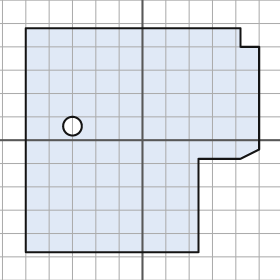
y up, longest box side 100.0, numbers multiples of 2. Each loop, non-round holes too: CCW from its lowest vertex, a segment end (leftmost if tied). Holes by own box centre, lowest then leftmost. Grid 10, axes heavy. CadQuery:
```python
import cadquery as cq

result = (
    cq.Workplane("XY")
    .moveTo(-50.0, -48.0)
    .lineTo(24.0, -48.0)
    .lineTo(24.0, -8.0)
    .lineTo(42.0, -8.0)
    .lineTo(50.0, -4.0)
    .lineTo(50.0, 40.0)
    .lineTo(42.0, 40.0)
    .lineTo(42.0, 48.0)
    .lineTo(-50.0, 48.0)
    .close()
    .moveTo(-30.0, 6.0)
    .circle(4.0)
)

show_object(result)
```